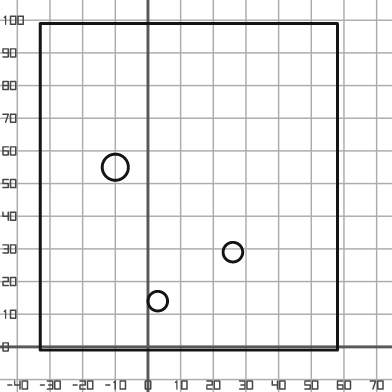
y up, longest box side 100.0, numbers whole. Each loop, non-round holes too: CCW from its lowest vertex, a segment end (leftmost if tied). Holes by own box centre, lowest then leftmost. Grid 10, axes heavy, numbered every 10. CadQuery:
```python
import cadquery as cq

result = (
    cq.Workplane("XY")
    .moveTo(-33.0, -1.0)
    .lineTo(58.0, -1.0)
    .lineTo(58.0, 99.0)
    .lineTo(-33.0, 99.0)
    .close()
    .moveTo(3.0, 14.0)
    .circle(3.0)
    .moveTo(26.0, 29.0)
    .circle(3.0)
    .moveTo(-10.0, 55.0)
    .circle(4.0)
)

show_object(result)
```